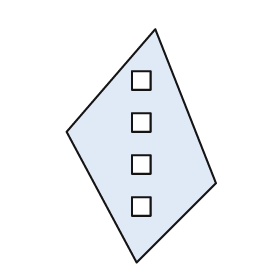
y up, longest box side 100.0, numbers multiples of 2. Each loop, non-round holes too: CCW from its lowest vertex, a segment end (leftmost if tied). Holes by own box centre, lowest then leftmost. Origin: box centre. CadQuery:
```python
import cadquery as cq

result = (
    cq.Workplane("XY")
    .moveTo(-2.0, -50.0)
    .lineTo(32.0, -16.0)
    .lineTo(6.0, 50.0)
    .lineTo(-32.0, 6.0)
    .close()
    .moveTo(-4.0, -30.0)
    .lineTo(4.0, -30.0)
    .lineTo(4.0, -22.0)
    .lineTo(-4.0, -22.0)
    .close()
    .moveTo(-4.0, -12.0)
    .lineTo(4.0, -12.0)
    .lineTo(4.0, -4.0)
    .lineTo(-4.0, -4.0)
    .close()
    .moveTo(-4.0, 6.0)
    .lineTo(4.0, 6.0)
    .lineTo(4.0, 14.0)
    .lineTo(-4.0, 14.0)
    .close()
    .moveTo(-4.0, 24.0)
    .lineTo(4.0, 24.0)
    .lineTo(4.0, 32.0)
    .lineTo(-4.0, 32.0)
    .close()
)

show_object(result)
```